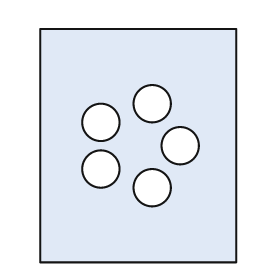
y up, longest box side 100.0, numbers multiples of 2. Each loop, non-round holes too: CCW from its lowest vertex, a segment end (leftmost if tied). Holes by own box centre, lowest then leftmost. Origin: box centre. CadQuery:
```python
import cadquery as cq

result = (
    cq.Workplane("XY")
    .moveTo(-42.0, -50.0)
    .lineTo(42.0, -50.0)
    .lineTo(42.0, 50.0)
    .lineTo(-42.0, 50.0)
    .close()
    .moveTo(6.0, -18.0)
    .circle(8.0)
    .moveTo(-16.0, -10.0)
    .circle(8.0)
    .moveTo(18.0, 0.0)
    .circle(8.0)
    .moveTo(-16.0, 10.0)
    .circle(8.0)
    .moveTo(6.0, 18.0)
    .circle(8.0)
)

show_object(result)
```